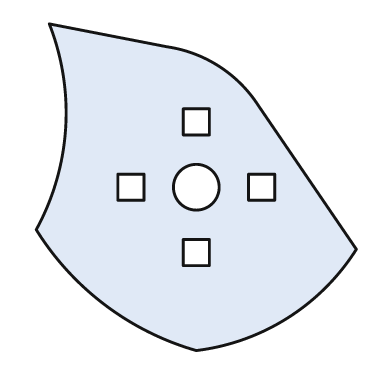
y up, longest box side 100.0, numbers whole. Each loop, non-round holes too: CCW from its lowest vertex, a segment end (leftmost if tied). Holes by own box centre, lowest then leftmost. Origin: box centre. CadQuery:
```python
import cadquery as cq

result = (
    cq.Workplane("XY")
    .moveTo(0.0, -50.0)
    .threePointArc((28.0, -40.0), (49.0, -19.0))
    .lineTo(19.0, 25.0)
    .threePointArc((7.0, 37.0), (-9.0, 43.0))
    .lineTo(-45.0, 50.0)
    .threePointArc((-40.0, 18.0), (-49.0, -13.0))
    .threePointArc((-28.0, -36.0), (0.0, -50.0))
    .close()
    .moveTo(-4.0, -24.0)
    .lineTo(4.0, -24.0)
    .lineTo(4.0, -16.0)
    .lineTo(-4.0, -16.0)
    .close()
    .moveTo(-24.0, -4.0)
    .lineTo(-16.0, -4.0)
    .lineTo(-16.0, 4.0)
    .lineTo(-24.0, 4.0)
    .close()
    .moveTo(0.0, 0.0)
    .circle(7.0)
    .moveTo(16.0, -4.0)
    .lineTo(24.0, -4.0)
    .lineTo(24.0, 4.0)
    .lineTo(16.0, 4.0)
    .close()
    .moveTo(-4.0, 16.0)
    .lineTo(4.0, 16.0)
    .lineTo(4.0, 24.0)
    .lineTo(-4.0, 24.0)
    .close()
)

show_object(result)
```